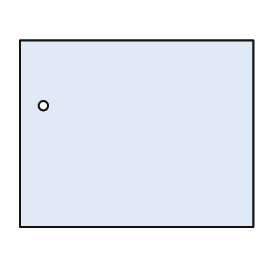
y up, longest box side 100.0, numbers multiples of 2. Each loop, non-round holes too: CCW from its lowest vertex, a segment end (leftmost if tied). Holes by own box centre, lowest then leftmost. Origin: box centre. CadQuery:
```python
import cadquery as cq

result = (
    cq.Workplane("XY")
    .moveTo(-50.0, -40.0)
    .lineTo(50.0, -40.0)
    .lineTo(50.0, 40.0)
    .lineTo(-50.0, 40.0)
    .close()
    .moveTo(-40.0, 12.0)
    .circle(2.0)
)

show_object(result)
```